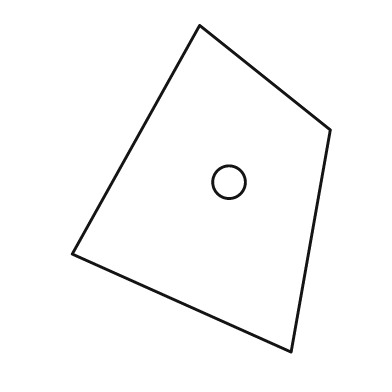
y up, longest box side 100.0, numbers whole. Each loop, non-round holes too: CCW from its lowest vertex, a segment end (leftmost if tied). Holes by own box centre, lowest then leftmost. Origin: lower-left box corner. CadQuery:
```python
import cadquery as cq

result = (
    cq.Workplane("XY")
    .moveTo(67.0, 0.0)
    .lineTo(79.0, 68.0)
    .lineTo(39.0, 100.0)
    .lineTo(0.0, 30.0)
    .close()
    .moveTo(48.0, 52.0)
    .circle(5.0)
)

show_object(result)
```